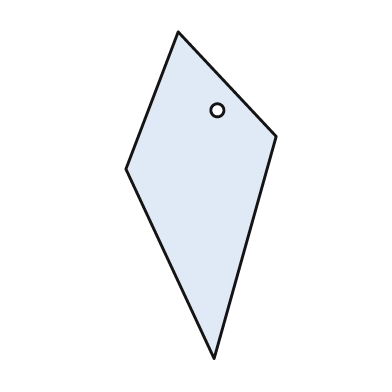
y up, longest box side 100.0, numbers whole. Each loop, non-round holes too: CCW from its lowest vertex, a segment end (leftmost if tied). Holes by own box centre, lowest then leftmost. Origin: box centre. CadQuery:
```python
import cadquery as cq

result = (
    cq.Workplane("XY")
    .moveTo(4.0, -50.0)
    .lineTo(23.0, 18.0)
    .lineTo(-7.0, 50.0)
    .lineTo(-23.0, 8.0)
    .close()
    .moveTo(5.0, 26.0)
    .circle(2.0)
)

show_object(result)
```